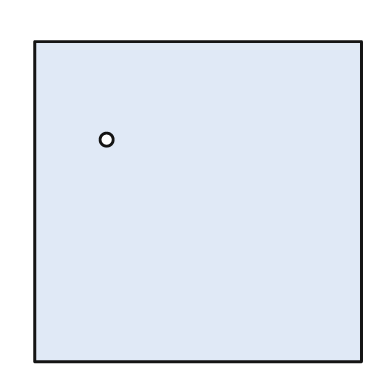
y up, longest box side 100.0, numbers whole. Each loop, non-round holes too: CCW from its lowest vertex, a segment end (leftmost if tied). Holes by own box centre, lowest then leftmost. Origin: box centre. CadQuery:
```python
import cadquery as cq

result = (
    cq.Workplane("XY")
    .moveTo(-50.0, -49.0)
    .lineTo(50.0, -49.0)
    .lineTo(50.0, 49.0)
    .lineTo(-50.0, 49.0)
    .close()
    .moveTo(-28.0, 19.0)
    .circle(2.0)
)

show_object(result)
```